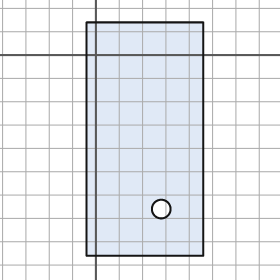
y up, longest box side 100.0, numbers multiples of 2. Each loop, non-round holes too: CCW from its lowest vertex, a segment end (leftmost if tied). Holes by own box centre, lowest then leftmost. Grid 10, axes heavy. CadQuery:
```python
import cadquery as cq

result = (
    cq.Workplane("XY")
    .moveTo(-4.0, -86.0)
    .lineTo(46.0, -86.0)
    .lineTo(46.0, 14.0)
    .lineTo(-4.0, 14.0)
    .close()
    .moveTo(28.0, -66.0)
    .circle(4.0)
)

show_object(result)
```